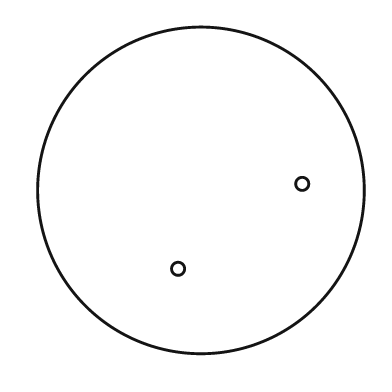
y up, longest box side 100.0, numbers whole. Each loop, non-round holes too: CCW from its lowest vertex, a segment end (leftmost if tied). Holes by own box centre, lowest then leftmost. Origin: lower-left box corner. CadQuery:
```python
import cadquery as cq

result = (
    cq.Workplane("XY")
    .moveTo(50.0, 50.0)
    .circle(50.0)
    .moveTo(43.0, 26.0)
    .circle(2.0)
    .moveTo(81.0, 52.0)
    .circle(2.0)
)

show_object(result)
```